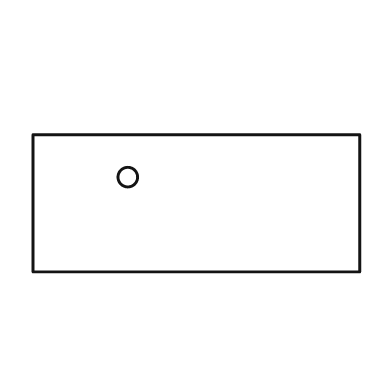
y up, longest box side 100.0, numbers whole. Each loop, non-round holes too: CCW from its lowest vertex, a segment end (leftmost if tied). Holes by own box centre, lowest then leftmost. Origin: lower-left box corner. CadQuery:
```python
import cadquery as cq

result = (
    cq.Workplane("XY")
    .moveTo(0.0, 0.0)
    .lineTo(100.0, 0.0)
    .lineTo(100.0, 42.0)
    .lineTo(0.0, 42.0)
    .close()
    .moveTo(29.0, 29.0)
    .circle(3.0)
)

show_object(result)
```